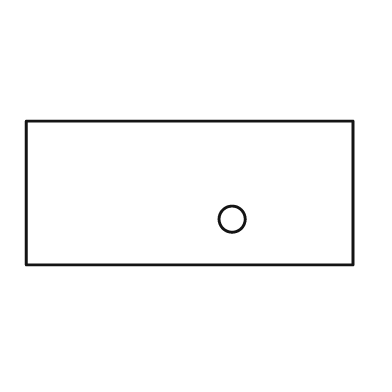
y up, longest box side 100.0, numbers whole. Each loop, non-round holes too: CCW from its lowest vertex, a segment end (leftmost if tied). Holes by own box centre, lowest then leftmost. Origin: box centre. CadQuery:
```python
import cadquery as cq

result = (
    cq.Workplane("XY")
    .moveTo(-50.0, -22.0)
    .lineTo(50.0, -22.0)
    .lineTo(50.0, 22.0)
    .lineTo(-50.0, 22.0)
    .close()
    .moveTo(13.0, -8.0)
    .circle(4.0)
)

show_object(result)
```